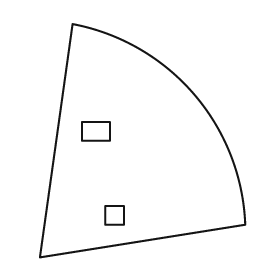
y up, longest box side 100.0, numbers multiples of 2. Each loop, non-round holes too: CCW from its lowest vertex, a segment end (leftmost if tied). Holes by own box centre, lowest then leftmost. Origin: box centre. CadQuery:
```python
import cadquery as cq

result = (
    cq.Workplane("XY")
    .moveTo(-44.0, -50.0)
    .lineTo(44.0, -36.0)
    .threePointArc((22.0, 20.0), (-30.0, 50.0))
    .close()
    .moveTo(-16.0, -36.0)
    .lineTo(-8.0, -36.0)
    .lineTo(-8.0, -28.0)
    .lineTo(-16.0, -28.0)
    .close()
    .moveTo(-26.0, 0.0)
    .lineTo(-14.0, 0.0)
    .lineTo(-14.0, 8.0)
    .lineTo(-26.0, 8.0)
    .close()
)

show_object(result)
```